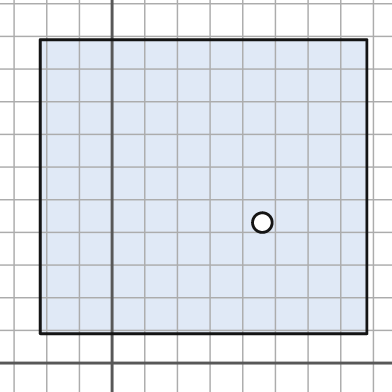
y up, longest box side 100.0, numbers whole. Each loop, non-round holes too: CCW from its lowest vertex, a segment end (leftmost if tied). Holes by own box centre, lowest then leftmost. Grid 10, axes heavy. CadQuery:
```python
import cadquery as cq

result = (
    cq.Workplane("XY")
    .moveTo(-22.0, 9.0)
    .lineTo(78.0, 9.0)
    .lineTo(78.0, 99.0)
    .lineTo(-22.0, 99.0)
    .close()
    .moveTo(46.0, 43.0)
    .circle(3.0)
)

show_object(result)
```